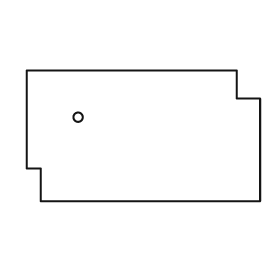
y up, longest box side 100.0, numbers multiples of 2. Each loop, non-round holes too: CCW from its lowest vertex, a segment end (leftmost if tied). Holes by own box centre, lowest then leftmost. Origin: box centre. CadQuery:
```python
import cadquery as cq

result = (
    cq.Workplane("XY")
    .moveTo(-44.0, -28.0)
    .lineTo(50.0, -28.0)
    .lineTo(50.0, 16.0)
    .lineTo(40.0, 16.0)
    .lineTo(40.0, 28.0)
    .lineTo(-50.0, 28.0)
    .lineTo(-50.0, -14.0)
    .lineTo(-44.0, -14.0)
    .close()
    .moveTo(-28.0, 8.0)
    .circle(2.0)
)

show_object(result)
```